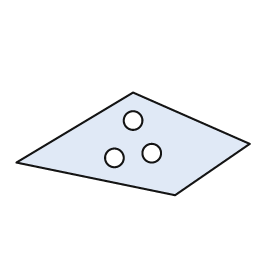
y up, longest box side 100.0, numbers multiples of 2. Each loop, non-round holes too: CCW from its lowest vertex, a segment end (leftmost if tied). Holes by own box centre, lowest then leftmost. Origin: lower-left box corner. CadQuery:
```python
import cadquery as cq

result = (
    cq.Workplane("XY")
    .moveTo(68.0, 0.0)
    .lineTo(100.0, 22.0)
    .lineTo(50.0, 44.0)
    .lineTo(0.0, 14.0)
    .close()
    .moveTo(42.0, 16.0)
    .circle(4.0)
    .moveTo(58.0, 18.0)
    .circle(4.0)
    .moveTo(50.0, 32.0)
    .circle(4.0)
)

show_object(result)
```